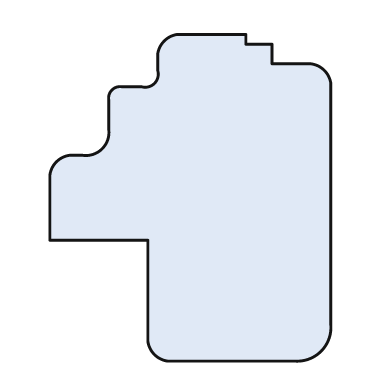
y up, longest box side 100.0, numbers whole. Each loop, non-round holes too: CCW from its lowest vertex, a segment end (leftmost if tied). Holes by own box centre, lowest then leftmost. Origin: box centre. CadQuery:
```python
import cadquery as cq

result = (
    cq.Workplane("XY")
    .moveTo(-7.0, -50.0)
    .lineTo(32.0, -50.0)
    .threePointArc((40.0, -47.0), (43.0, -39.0))
    .lineTo(43.0, 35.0)
    .threePointArc((41.0, 39.0), (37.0, 41.0))
    .lineTo(25.0, 41.0)
    .lineTo(25.0, 47.0)
    .lineTo(17.0, 47.0)
    .lineTo(17.0, 50.0)
    .lineTo(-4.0, 50.0)
    .threePointArc((-8.0, 48.0), (-10.0, 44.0))
    .lineTo(-10.0, 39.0)
    .threePointArc((-11.0, 35.0), (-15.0, 34.0))
    .lineTo(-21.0, 34.0)
    .threePointArc((-24.0, 33.0), (-25.0, 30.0))
    .lineTo(-25.0, 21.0)
    .threePointArc((-27.0, 15.0), (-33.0, 13.0))
    .lineTo(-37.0, 13.0)
    .threePointArc((-41.0, 11.0), (-43.0, 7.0))
    .lineTo(-43.0, -13.0)
    .lineTo(-13.0, -13.0)
    .lineTo(-13.0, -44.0)
    .threePointArc((-11.0, -48.0), (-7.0, -50.0))
    .close()
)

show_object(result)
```